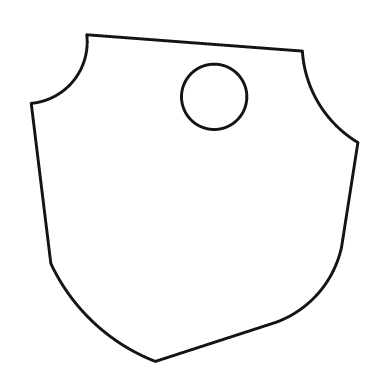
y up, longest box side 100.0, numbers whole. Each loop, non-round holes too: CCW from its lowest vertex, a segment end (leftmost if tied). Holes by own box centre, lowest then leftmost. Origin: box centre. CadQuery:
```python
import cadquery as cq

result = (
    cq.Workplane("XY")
    .moveTo(-12.0, -50.0)
    .lineTo(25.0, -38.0)
    .threePointArc((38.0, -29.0), (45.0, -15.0))
    .lineTo(50.0, 17.0)
    .threePointArc((38.0, 29.0), (33.0, 45.0))
    .lineTo(-33.0, 50.0)
    .threePointArc((-37.0, 36.0), (-50.0, 29.0))
    .lineTo(-44.0, -20.0)
    .threePointArc((-31.0, -38.0), (-12.0, -50.0))
    .close()
    .moveTo(6.0, 31.0)
    .circle(10.0)
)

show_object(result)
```